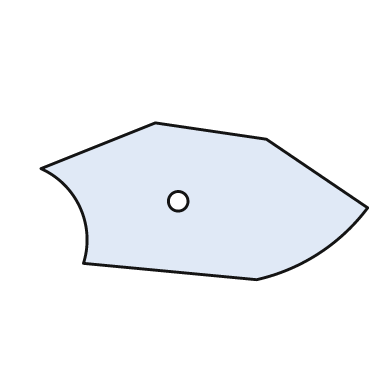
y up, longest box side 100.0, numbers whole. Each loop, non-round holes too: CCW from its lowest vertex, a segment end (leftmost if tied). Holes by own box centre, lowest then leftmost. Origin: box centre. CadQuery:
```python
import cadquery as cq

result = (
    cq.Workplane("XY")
    .moveTo(16.0, -24.0)
    .threePointArc((35.0, -16.0), (50.0, -2.0))
    .lineTo(19.0, 19.0)
    .lineTo(-15.0, 24.0)
    .lineTo(-50.0, 10.0)
    .threePointArc((-38.0, -2.0), (-37.0, -19.0))
    .close()
    .moveTo(-8.0, 0.0)
    .circle(3.0)
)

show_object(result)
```